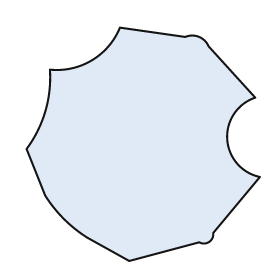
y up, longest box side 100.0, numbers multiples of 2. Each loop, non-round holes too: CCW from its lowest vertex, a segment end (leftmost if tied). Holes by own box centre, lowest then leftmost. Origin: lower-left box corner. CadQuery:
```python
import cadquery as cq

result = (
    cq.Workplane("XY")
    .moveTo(44.0, 0.0)
    .lineTo(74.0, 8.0)
    .threePointArc((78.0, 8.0), (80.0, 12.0))
    .lineTo(100.0, 36.0)
    .threePointArc((86.0, 52.0), (98.0, 70.0))
    .lineTo(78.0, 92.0)
    .threePointArc((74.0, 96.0), (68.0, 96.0))
    .lineTo(40.0, 100.0)
    .threePointArc((28.0, 86.0), (10.0, 82.0))
    .threePointArc((8.0, 64.0), (0.0, 48.0))
    .lineTo(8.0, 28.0)
    .threePointArc((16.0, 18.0), (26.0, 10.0))
    .close()
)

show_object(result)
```